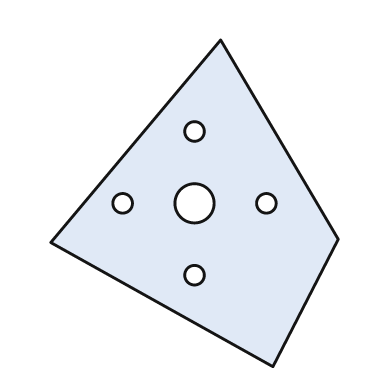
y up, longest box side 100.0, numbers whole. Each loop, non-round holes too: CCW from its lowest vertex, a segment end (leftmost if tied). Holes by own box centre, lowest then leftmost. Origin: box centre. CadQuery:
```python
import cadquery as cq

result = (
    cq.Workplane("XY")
    .moveTo(24.0, -50.0)
    .lineTo(44.0, -11.0)
    .lineTo(8.0, 50.0)
    .lineTo(-44.0, -12.0)
    .close()
    .moveTo(0.0, -22.0)
    .circle(3.0)
    .moveTo(-22.0, 0.0)
    .circle(3.0)
    .moveTo(0.0, 0.0)
    .circle(6.0)
    .moveTo(22.0, 0.0)
    .circle(3.0)
    .moveTo(0.0, 22.0)
    .circle(3.0)
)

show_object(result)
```